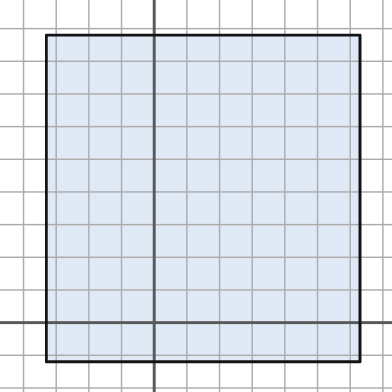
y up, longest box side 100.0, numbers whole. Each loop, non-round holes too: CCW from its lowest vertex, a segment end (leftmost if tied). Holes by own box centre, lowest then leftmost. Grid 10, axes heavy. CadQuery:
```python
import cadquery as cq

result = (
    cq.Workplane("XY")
    .moveTo(-33.0, -12.0)
    .lineTo(63.0, -12.0)
    .lineTo(63.0, 88.0)
    .lineTo(-33.0, 88.0)
    .close()
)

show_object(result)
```